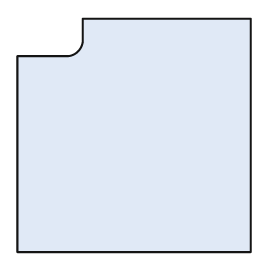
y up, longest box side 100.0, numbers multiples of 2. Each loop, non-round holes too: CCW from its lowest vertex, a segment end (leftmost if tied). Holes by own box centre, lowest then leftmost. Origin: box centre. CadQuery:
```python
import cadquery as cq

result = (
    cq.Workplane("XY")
    .moveTo(-50.0, -50.0)
    .lineTo(50.0, -50.0)
    .lineTo(50.0, 50.0)
    .lineTo(-22.0, 50.0)
    .lineTo(-22.0, 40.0)
    .threePointArc((-24.0, 36.0), (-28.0, 34.0))
    .lineTo(-50.0, 34.0)
    .close()
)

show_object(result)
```